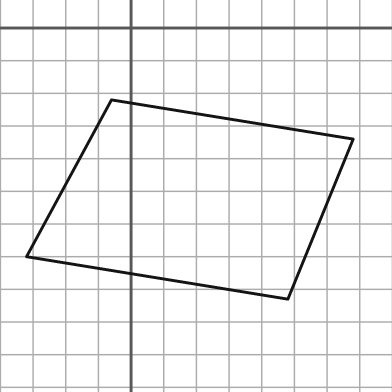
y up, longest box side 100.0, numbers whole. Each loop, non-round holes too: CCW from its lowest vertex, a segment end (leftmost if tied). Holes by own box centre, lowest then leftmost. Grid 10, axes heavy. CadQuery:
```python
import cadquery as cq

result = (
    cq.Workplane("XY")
    .moveTo(48.0, -83.0)
    .lineTo(68.0, -34.0)
    .lineTo(-6.0, -22.0)
    .lineTo(-32.0, -70.0)
    .close()
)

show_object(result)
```